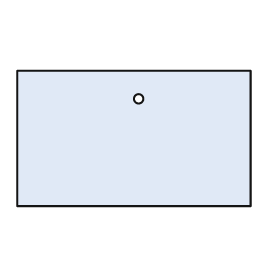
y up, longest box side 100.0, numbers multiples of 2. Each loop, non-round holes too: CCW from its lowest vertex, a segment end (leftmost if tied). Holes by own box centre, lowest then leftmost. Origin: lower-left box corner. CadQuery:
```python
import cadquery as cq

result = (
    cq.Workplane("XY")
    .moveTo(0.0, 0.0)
    .lineTo(100.0, 0.0)
    .lineTo(100.0, 58.0)
    .lineTo(0.0, 58.0)
    .close()
    .moveTo(52.0, 46.0)
    .circle(2.0)
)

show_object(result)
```